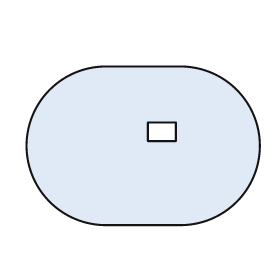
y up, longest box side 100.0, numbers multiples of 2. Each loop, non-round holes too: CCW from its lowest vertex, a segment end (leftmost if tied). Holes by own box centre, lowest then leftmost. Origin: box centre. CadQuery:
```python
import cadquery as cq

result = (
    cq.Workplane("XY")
    .moveTo(-16.0, -34.0)
    .lineTo(16.0, -34.0)
    .threePointArc((50.0, 0.0), (16.0, 34.0))
    .lineTo(-16.0, 34.0)
    .threePointArc((-50.0, 0.0), (-16.0, -34.0))
    .close()
    .moveTo(2.0, 2.0)
    .lineTo(14.0, 2.0)
    .lineTo(14.0, 10.0)
    .lineTo(2.0, 10.0)
    .close()
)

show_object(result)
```